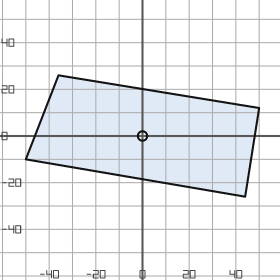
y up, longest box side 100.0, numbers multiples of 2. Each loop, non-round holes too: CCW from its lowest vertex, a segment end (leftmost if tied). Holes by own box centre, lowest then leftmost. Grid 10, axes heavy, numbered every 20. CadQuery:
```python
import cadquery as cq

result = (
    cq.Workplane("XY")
    .moveTo(44.0, -26.0)
    .lineTo(50.0, 12.0)
    .lineTo(-36.0, 26.0)
    .lineTo(-50.0, -10.0)
    .close()
    .moveTo(0.0, 0.0)
    .circle(2.0)
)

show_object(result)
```